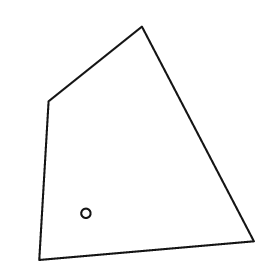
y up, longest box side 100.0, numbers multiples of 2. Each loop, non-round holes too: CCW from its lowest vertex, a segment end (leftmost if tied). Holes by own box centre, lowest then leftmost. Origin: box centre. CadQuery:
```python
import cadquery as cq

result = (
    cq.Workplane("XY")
    .moveTo(-46.0, -50.0)
    .lineTo(46.0, -42.0)
    .lineTo(-2.0, 50.0)
    .lineTo(-42.0, 18.0)
    .close()
    .moveTo(-26.0, -30.0)
    .circle(2.0)
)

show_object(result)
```